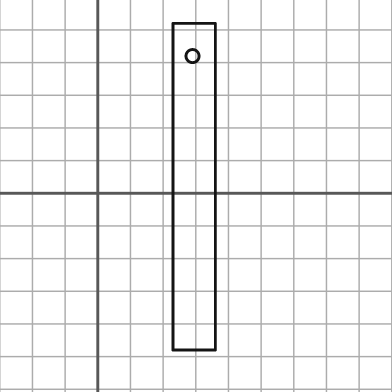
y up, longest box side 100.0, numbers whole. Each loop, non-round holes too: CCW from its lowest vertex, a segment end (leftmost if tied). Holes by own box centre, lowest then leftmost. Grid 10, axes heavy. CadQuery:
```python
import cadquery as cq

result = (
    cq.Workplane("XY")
    .moveTo(23.0, -48.0)
    .lineTo(36.0, -48.0)
    .lineTo(36.0, 52.0)
    .lineTo(23.0, 52.0)
    .close()
    .moveTo(29.0, 42.0)
    .circle(2.0)
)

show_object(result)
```